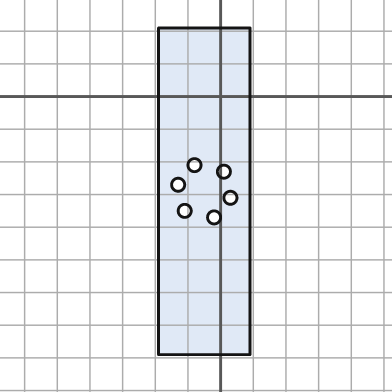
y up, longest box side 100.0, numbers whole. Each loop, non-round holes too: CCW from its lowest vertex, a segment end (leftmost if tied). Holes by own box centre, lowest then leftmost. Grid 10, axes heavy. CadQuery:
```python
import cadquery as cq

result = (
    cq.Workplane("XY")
    .moveTo(-19.0, -79.0)
    .lineTo(9.0, -79.0)
    .lineTo(9.0, 21.0)
    .lineTo(-19.0, 21.0)
    .close()
    .moveTo(-2.0, -37.0)
    .circle(2.0)
    .moveTo(-11.0, -35.0)
    .circle(2.0)
    .moveTo(3.0, -31.0)
    .circle(2.0)
    .moveTo(-13.0, -27.0)
    .circle(2.0)
    .moveTo(1.0, -23.0)
    .circle(2.0)
    .moveTo(-8.0, -21.0)
    .circle(2.0)
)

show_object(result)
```